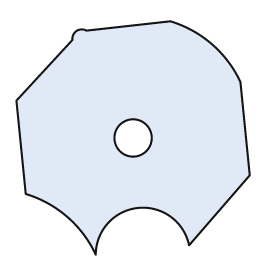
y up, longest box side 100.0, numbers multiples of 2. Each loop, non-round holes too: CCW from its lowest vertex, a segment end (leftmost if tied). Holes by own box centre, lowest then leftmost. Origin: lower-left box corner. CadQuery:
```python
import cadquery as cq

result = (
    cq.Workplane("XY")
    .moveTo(34.0, 0.0)
    .threePointArc((52.0, 20.0), (74.0, 4.0))
    .lineTo(100.0, 34.0)
    .lineTo(96.0, 74.0)
    .threePointArc((84.0, 90.0), (66.0, 100.0))
    .lineTo(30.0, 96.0)
    .threePointArc((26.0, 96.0), (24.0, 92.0))
    .lineTo(0.0, 66.0)
    .lineTo(4.0, 26.0)
    .threePointArc((22.0, 16.0), (34.0, 0.0))
    .close()
    .moveTo(50.0, 50.0)
    .circle(8.0)
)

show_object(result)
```